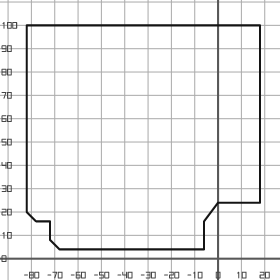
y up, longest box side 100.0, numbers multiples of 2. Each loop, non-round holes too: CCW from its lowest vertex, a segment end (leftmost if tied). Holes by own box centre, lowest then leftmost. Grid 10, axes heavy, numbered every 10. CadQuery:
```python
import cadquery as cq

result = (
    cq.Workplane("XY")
    .moveTo(-68.0, 4.0)
    .lineTo(-6.0, 4.0)
    .lineTo(-6.0, 16.0)
    .lineTo(0.0, 24.0)
    .lineTo(18.0, 24.0)
    .lineTo(18.0, 100.0)
    .lineTo(-82.0, 100.0)
    .lineTo(-82.0, 20.0)
    .lineTo(-78.0, 16.0)
    .lineTo(-72.0, 16.0)
    .lineTo(-72.0, 8.0)
    .close()
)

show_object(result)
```